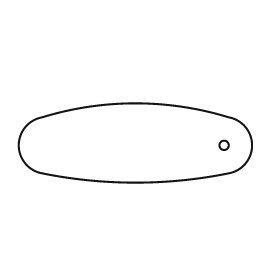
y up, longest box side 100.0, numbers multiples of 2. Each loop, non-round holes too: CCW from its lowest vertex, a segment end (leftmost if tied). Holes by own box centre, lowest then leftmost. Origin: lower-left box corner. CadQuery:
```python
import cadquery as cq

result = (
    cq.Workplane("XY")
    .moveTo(10.0, 4.0)
    .threePointArc((50.0, 0.0), (90.0, 4.0))
    .threePointArc((100.0, 16.0), (90.0, 28.0))
    .threePointArc((50.0, 34.0), (10.0, 28.0))
    .threePointArc((0.0, 16.0), (10.0, 4.0))
    .close()
    .moveTo(88.0, 16.0)
    .circle(2.0)
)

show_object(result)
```